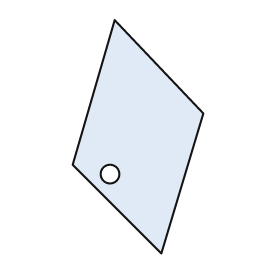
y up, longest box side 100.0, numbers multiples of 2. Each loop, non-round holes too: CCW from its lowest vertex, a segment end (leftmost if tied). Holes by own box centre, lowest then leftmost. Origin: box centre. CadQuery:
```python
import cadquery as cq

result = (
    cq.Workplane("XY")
    .moveTo(10.0, -50.0)
    .lineTo(28.0, 10.0)
    .lineTo(-10.0, 50.0)
    .lineTo(-28.0, -12.0)
    .close()
    .moveTo(-12.0, -16.0)
    .circle(4.0)
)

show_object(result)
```